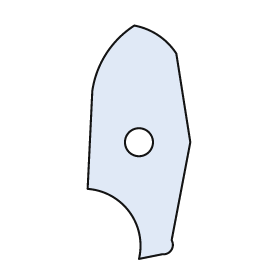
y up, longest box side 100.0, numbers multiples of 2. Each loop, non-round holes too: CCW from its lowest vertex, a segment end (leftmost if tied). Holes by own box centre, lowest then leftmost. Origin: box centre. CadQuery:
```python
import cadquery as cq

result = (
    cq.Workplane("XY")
    .moveTo(0.0, -50.0)
    .lineTo(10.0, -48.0)
    .threePointArc((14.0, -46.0), (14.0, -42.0))
    .lineTo(22.0, 0.0)
    .lineTo(16.0, 38.0)
    .threePointArc((8.0, 46.0), (-2.0, 50.0))
    .threePointArc((-14.0, 38.0), (-20.0, 22.0))
    .lineTo(-22.0, -20.0)
    .threePointArc((-4.0, -30.0), (0.0, -50.0))
    .close()
    .moveTo(0.0, 0.0)
    .circle(6.0)
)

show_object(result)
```